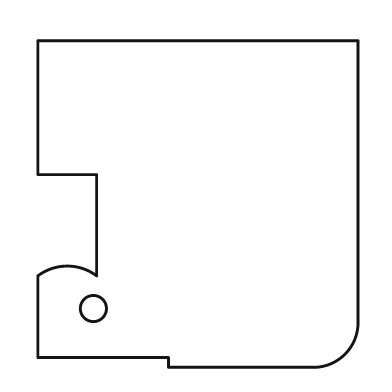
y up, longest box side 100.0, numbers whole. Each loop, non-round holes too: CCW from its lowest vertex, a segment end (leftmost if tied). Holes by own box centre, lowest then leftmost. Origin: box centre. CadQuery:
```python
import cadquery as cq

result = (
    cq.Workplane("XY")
    .moveTo(-9.0, -50.0)
    .lineTo(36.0, -50.0)
    .threePointArc((45.0, -46.0), (49.0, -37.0))
    .lineTo(49.0, 50.0)
    .lineTo(-49.0, 50.0)
    .lineTo(-49.0, 9.0)
    .lineTo(-31.0, 9.0)
    .lineTo(-31.0, -22.0)
    .threePointArc((-40.0, -19.0), (-49.0, -22.0))
    .lineTo(-49.0, -47.0)
    .lineTo(-9.0, -47.0)
    .close()
    .moveTo(-32.0, -32.0)
    .circle(4.0)
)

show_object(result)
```